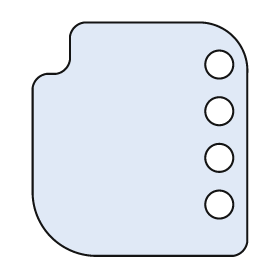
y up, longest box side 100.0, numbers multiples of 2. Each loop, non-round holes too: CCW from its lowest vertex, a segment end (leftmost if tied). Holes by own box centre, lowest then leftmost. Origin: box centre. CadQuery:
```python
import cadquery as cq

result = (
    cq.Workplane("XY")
    .moveTo(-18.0, -50.0)
    .lineTo(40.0, -50.0)
    .threePointArc((44.0, -48.0), (46.0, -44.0))
    .lineTo(46.0, 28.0)
    .threePointArc((40.0, 44.0), (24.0, 50.0))
    .lineTo(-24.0, 50.0)
    .threePointArc((-28.0, 48.0), (-30.0, 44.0))
    .lineTo(-30.0, 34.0)
    .threePointArc((-32.0, 30.0), (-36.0, 28.0))
    .lineTo(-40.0, 28.0)
    .threePointArc((-44.0, 26.0), (-46.0, 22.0))
    .lineTo(-46.0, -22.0)
    .threePointArc((-38.0, -42.0), (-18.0, -50.0))
    .close()
    .moveTo(34.0, -28.0)
    .circle(6.0)
    .moveTo(34.0, -8.0)
    .circle(6.0)
    .moveTo(34.0, 12.0)
    .circle(6.0)
    .moveTo(34.0, 32.0)
    .circle(6.0)
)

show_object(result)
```